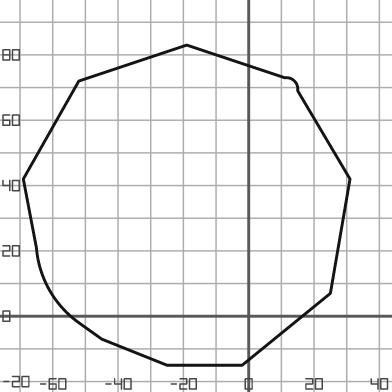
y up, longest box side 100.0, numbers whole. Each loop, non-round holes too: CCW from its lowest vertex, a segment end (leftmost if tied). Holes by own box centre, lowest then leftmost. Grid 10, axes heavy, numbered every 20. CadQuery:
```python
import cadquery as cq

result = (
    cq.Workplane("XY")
    .moveTo(-25.0, -15.0)
    .lineTo(-2.0, -15.0)
    .lineTo(25.0, 7.0)
    .lineTo(31.0, 42.0)
    .lineTo(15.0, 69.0)
    .threePointArc((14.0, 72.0), (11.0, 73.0))
    .lineTo(-19.0, 83.0)
    .lineTo(-52.0, 72.0)
    .lineTo(-69.0, 42.0)
    .lineTo(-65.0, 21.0)
    .threePointArc((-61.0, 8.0), (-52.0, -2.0))
    .lineTo(-45.0, -7.0)
    .close()
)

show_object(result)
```